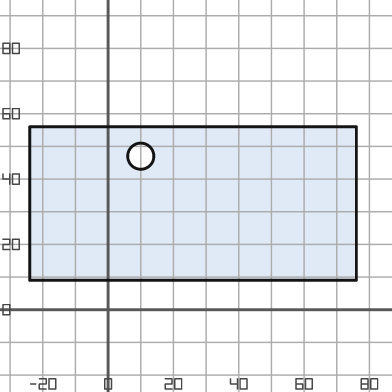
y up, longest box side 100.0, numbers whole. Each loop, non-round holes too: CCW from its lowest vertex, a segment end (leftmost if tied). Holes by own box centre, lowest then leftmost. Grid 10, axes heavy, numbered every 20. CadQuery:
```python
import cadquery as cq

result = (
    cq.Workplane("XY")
    .moveTo(-24.0, 9.0)
    .lineTo(76.0, 9.0)
    .lineTo(76.0, 56.0)
    .lineTo(-24.0, 56.0)
    .close()
    .moveTo(10.0, 47.0)
    .circle(4.0)
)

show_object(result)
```